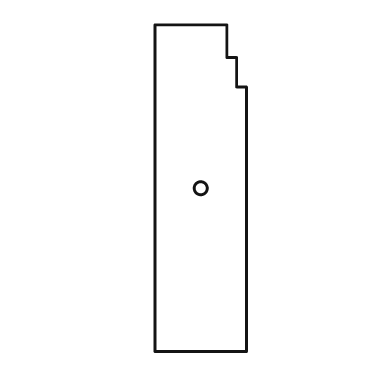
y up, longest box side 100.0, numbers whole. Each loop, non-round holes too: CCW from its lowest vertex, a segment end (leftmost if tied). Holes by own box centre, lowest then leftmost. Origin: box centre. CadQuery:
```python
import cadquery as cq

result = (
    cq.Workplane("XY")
    .moveTo(-14.0, -50.0)
    .lineTo(14.0, -50.0)
    .lineTo(14.0, 31.0)
    .lineTo(11.0, 31.0)
    .lineTo(11.0, 40.0)
    .lineTo(8.0, 40.0)
    .lineTo(8.0, 50.0)
    .lineTo(-14.0, 50.0)
    .close()
    .moveTo(0.0, 0.0)
    .circle(2.0)
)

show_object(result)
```